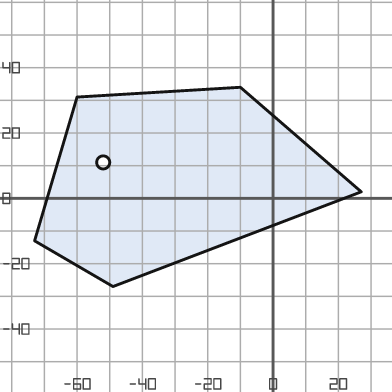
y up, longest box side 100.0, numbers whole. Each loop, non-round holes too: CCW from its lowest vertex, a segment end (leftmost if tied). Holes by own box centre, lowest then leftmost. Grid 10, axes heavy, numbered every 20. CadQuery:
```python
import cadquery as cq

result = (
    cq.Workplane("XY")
    .moveTo(-49.0, -27.0)
    .lineTo(27.0, 2.0)
    .lineTo(-10.0, 34.0)
    .lineTo(-60.0, 31.0)
    .lineTo(-73.0, -13.0)
    .close()
    .moveTo(-52.0, 11.0)
    .circle(2.0)
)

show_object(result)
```